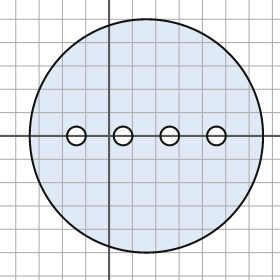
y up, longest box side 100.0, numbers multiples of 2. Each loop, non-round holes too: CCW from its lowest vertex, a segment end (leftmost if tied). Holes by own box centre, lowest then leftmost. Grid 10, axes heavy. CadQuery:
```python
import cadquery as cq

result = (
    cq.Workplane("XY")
    .moveTo(16.0, 0.0)
    .circle(50.0)
    .moveTo(-14.0, 0.0)
    .circle(4.0)
    .moveTo(6.0, 0.0)
    .circle(4.0)
    .moveTo(26.0, 0.0)
    .circle(4.0)
    .moveTo(46.0, 0.0)
    .circle(4.0)
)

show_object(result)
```